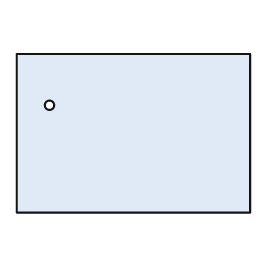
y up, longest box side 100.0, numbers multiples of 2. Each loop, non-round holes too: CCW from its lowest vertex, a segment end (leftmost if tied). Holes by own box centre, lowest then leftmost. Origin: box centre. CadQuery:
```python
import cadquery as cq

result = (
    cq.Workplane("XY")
    .moveTo(-50.0, -34.0)
    .lineTo(50.0, -34.0)
    .lineTo(50.0, 34.0)
    .lineTo(-50.0, 34.0)
    .close()
    .moveTo(-36.0, 12.0)
    .circle(2.0)
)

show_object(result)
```